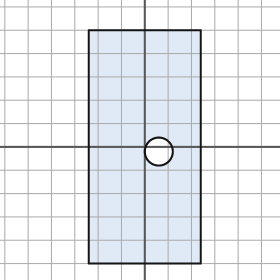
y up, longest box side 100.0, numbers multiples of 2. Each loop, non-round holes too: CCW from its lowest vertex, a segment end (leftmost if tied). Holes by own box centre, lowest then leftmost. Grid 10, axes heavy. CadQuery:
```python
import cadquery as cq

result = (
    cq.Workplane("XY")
    .moveTo(-24.0, -50.0)
    .lineTo(24.0, -50.0)
    .lineTo(24.0, 50.0)
    .lineTo(-24.0, 50.0)
    .close()
    .moveTo(6.0, -2.0)
    .circle(6.0)
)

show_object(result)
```